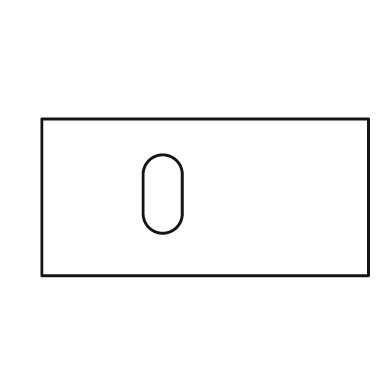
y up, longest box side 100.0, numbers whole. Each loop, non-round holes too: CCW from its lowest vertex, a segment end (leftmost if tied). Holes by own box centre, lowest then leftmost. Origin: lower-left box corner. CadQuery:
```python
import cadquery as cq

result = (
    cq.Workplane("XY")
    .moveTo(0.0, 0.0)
    .lineTo(100.0, 0.0)
    .lineTo(100.0, 48.0)
    .lineTo(0.0, 48.0)
    .close()
    .moveTo(31.0, 19.0)
    .threePointArc((37.0, 13.0), (43.0, 19.0))
    .lineTo(43.0, 31.0)
    .threePointArc((37.0, 37.0), (31.0, 31.0))
    .close()
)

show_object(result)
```